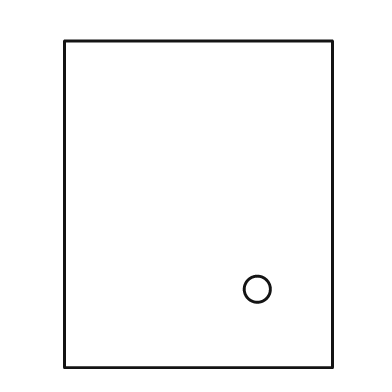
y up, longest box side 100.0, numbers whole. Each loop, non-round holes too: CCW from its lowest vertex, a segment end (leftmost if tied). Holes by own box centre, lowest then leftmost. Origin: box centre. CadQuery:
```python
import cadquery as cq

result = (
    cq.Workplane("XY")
    .moveTo(-41.0, -50.0)
    .lineTo(41.0, -50.0)
    .lineTo(41.0, 50.0)
    .lineTo(-41.0, 50.0)
    .close()
    .moveTo(18.0, -26.0)
    .circle(4.0)
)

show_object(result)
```